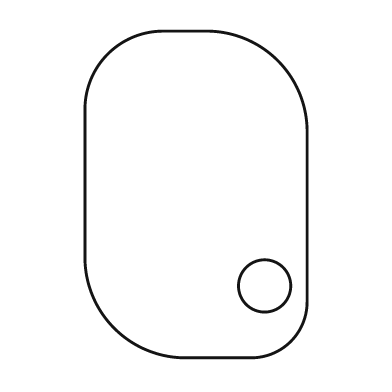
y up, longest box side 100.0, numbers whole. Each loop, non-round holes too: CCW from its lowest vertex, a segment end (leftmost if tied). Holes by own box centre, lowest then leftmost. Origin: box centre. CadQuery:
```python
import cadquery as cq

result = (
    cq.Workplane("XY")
    .moveTo(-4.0, -50.0)
    .lineTo(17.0, -50.0)
    .threePointArc((29.0, -45.0), (34.0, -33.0))
    .lineTo(34.0, 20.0)
    .threePointArc((25.0, 41.0), (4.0, 50.0))
    .lineTo(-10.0, 50.0)
    .threePointArc((-27.0, 43.0), (-34.0, 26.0))
    .lineTo(-34.0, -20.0)
    .threePointArc((-25.0, -41.0), (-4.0, -50.0))
    .close()
    .moveTo(21.0, -28.0)
    .circle(8.0)
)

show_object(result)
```